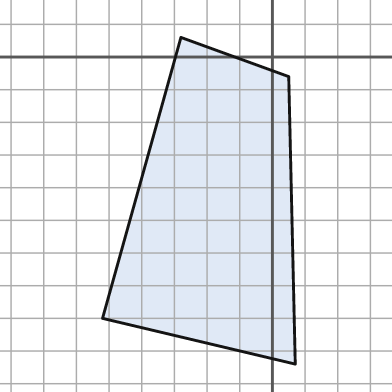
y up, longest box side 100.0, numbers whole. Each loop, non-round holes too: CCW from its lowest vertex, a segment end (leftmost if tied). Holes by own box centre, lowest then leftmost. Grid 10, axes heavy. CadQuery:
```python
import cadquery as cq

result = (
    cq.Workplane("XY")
    .moveTo(7.0, -94.0)
    .lineTo(5.0, -6.0)
    .lineTo(-28.0, 6.0)
    .lineTo(-52.0, -80.0)
    .close()
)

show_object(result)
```